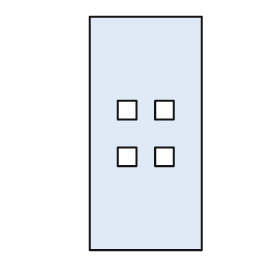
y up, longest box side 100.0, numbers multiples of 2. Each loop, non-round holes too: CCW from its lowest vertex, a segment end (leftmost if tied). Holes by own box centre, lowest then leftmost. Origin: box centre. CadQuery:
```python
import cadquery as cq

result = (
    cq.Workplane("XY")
    .moveTo(-24.0, -50.0)
    .lineTo(24.0, -50.0)
    .lineTo(24.0, 50.0)
    .lineTo(-24.0, 50.0)
    .close()
    .moveTo(-12.0, -14.0)
    .lineTo(-4.0, -14.0)
    .lineTo(-4.0, -6.0)
    .lineTo(-12.0, -6.0)
    .close()
    .moveTo(4.0, -14.0)
    .lineTo(12.0, -14.0)
    .lineTo(12.0, -6.0)
    .lineTo(4.0, -6.0)
    .close()
    .moveTo(-12.0, 6.0)
    .lineTo(-4.0, 6.0)
    .lineTo(-4.0, 14.0)
    .lineTo(-12.0, 14.0)
    .close()
    .moveTo(4.0, 6.0)
    .lineTo(12.0, 6.0)
    .lineTo(12.0, 14.0)
    .lineTo(4.0, 14.0)
    .close()
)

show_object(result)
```